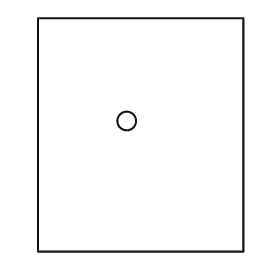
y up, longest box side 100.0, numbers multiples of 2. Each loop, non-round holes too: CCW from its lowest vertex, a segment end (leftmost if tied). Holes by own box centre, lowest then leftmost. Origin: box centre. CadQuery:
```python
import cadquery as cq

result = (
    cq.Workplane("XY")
    .moveTo(-44.0, -50.0)
    .lineTo(44.0, -50.0)
    .lineTo(44.0, 50.0)
    .lineTo(-44.0, 50.0)
    .close()
    .moveTo(-6.0, 6.0)
    .circle(4.0)
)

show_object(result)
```